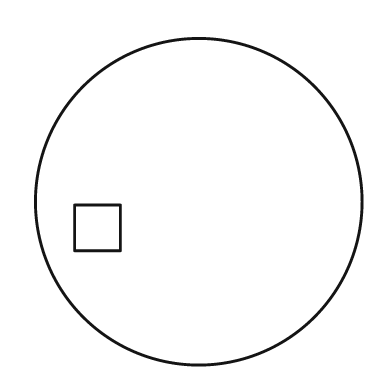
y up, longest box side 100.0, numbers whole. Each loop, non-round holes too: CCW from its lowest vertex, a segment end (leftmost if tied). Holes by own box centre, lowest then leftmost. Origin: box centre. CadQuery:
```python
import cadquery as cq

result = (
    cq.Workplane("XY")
    .moveTo(0.0, 0.0)
    .circle(50.0)
    .moveTo(-38.0, -15.0)
    .lineTo(-24.0, -15.0)
    .lineTo(-24.0, -1.0)
    .lineTo(-38.0, -1.0)
    .close()
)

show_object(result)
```